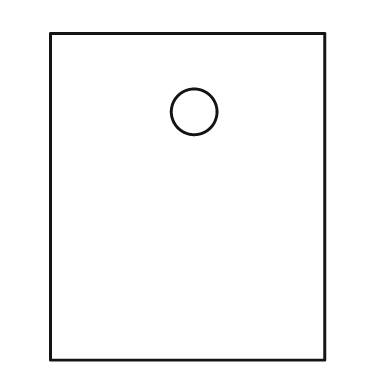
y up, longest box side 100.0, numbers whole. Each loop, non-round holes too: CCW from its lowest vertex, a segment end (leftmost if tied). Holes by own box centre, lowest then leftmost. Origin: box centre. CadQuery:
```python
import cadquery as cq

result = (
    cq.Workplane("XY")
    .moveTo(-42.0, -50.0)
    .lineTo(42.0, -50.0)
    .lineTo(42.0, 50.0)
    .lineTo(-42.0, 50.0)
    .close()
    .moveTo(2.0, 26.0)
    .circle(7.0)
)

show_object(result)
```